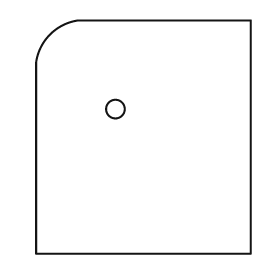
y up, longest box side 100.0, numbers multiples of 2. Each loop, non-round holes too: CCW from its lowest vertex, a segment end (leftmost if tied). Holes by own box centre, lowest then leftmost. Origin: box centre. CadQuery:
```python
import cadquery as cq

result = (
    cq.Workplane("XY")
    .moveTo(-46.0, -50.0)
    .lineTo(46.0, -50.0)
    .lineTo(46.0, 50.0)
    .lineTo(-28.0, 50.0)
    .threePointArc((-40.0, 44.0), (-46.0, 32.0))
    .close()
    .moveTo(-12.0, 12.0)
    .circle(4.0)
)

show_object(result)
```